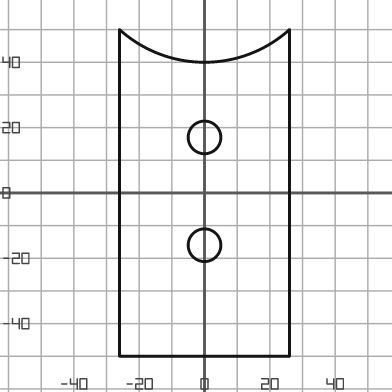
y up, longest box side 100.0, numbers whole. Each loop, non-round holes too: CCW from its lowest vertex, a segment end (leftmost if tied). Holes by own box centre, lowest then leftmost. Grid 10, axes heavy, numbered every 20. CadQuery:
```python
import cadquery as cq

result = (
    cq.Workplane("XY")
    .moveTo(-26.0, -50.0)
    .lineTo(26.0, -50.0)
    .lineTo(26.0, 50.0)
    .threePointArc((0.0, 40.0), (-26.0, 50.0))
    .close()
    .moveTo(0.0, -16.0)
    .circle(5.0)
    .moveTo(0.0, 17.0)
    .circle(5.0)
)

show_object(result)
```